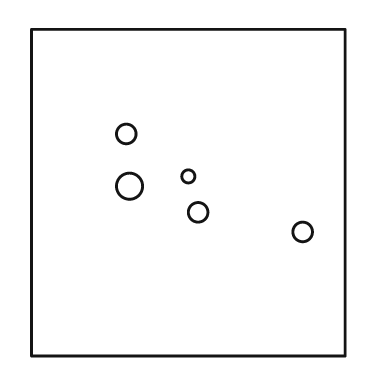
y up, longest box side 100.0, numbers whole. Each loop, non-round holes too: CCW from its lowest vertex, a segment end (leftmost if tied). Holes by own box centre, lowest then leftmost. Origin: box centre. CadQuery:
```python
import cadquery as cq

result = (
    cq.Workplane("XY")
    .moveTo(-48.0, -50.0)
    .lineTo(48.0, -50.0)
    .lineTo(48.0, 50.0)
    .lineTo(-48.0, 50.0)
    .close()
    .moveTo(35.0, -12.0)
    .circle(3.0)
    .moveTo(3.0, -6.0)
    .circle(3.0)
    .moveTo(-18.0, 2.0)
    .circle(4.0)
    .moveTo(0.0, 5.0)
    .circle(2.0)
    .moveTo(-19.0, 18.0)
    .circle(3.0)
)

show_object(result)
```